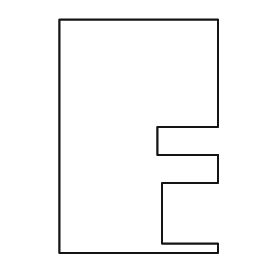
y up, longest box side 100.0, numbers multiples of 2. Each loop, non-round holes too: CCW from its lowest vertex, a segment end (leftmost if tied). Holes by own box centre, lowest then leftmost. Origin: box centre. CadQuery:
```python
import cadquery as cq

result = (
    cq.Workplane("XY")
    .moveTo(-34.0, -50.0)
    .lineTo(34.0, -50.0)
    .lineTo(34.0, -46.0)
    .lineTo(10.0, -46.0)
    .lineTo(10.0, -20.0)
    .lineTo(34.0, -20.0)
    .lineTo(34.0, -8.0)
    .lineTo(8.0, -8.0)
    .lineTo(8.0, 4.0)
    .lineTo(34.0, 4.0)
    .lineTo(34.0, 50.0)
    .lineTo(-34.0, 50.0)
    .close()
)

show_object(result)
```